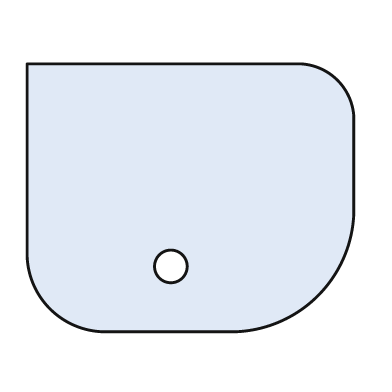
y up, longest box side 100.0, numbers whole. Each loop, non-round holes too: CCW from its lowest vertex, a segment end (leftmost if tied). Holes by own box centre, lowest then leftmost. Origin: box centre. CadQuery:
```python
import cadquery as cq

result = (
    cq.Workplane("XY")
    .moveTo(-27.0, -41.0)
    .lineTo(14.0, -41.0)
    .threePointArc((39.0, -30.0), (50.0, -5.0))
    .lineTo(50.0, 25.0)
    .threePointArc((45.0, 36.0), (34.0, 41.0))
    .lineTo(-50.0, 41.0)
    .lineTo(-50.0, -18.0)
    .threePointArc((-43.0, -34.0), (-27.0, -41.0))
    .close()
    .moveTo(-6.0, -21.0)
    .circle(5.0)
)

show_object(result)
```